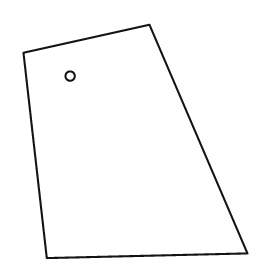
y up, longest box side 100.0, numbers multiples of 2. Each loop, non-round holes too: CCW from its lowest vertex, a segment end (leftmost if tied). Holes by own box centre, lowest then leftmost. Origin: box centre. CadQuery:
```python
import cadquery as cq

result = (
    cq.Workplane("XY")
    .moveTo(-38.0, -50.0)
    .lineTo(48.0, -48.0)
    .lineTo(6.0, 50.0)
    .lineTo(-48.0, 38.0)
    .close()
    .moveTo(-28.0, 28.0)
    .circle(2.0)
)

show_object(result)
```